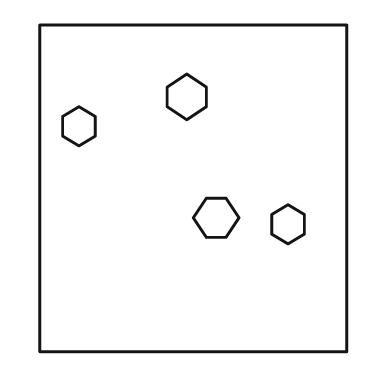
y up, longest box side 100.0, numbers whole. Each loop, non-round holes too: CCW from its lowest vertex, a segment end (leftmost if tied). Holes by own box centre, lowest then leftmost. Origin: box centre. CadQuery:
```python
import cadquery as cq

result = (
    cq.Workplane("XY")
    .moveTo(-47.0, -50.0)
    .lineTo(47.0, -50.0)
    .lineTo(47.0, 50.0)
    .lineTo(-47.0, 50.0)
    .close()
    .moveTo(29.0, -17.0)
    .lineTo(34.0, -14.0)
    .lineTo(34.0, -8.0)
    .lineTo(29.0, -5.0)
    .lineTo(24.0, -8.0)
    .lineTo(24.0, -14.0)
    .close()
    .moveTo(4.0, -15.0)
    .lineTo(10.0, -15.0)
    .lineTo(14.0, -9.0)
    .lineTo(10.0, -3.0)
    .lineTo(4.0, -3.0)
    .lineTo(0.0, -9.0)
    .close()
    .moveTo(-35.0, 13.0)
    .lineTo(-30.0, 16.0)
    .lineTo(-30.0, 22.0)
    .lineTo(-35.0, 25.0)
    .lineTo(-40.0, 22.0)
    .lineTo(-40.0, 16.0)
    .close()
    .moveTo(-2.0, 21.0)
    .lineTo(4.0, 25.0)
    .lineTo(4.0, 31.0)
    .lineTo(-2.0, 35.0)
    .lineTo(-8.0, 31.0)
    .lineTo(-8.0, 25.0)
    .close()
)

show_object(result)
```